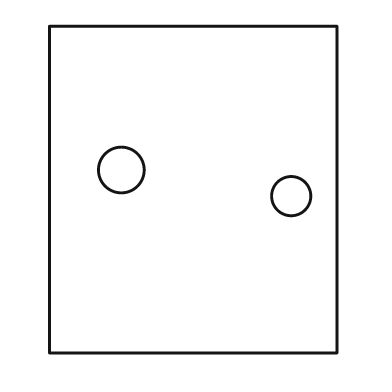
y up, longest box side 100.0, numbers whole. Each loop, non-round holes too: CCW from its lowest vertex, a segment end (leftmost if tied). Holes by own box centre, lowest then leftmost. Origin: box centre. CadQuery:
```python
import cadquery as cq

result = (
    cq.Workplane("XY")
    .moveTo(-44.0, -50.0)
    .lineTo(44.0, -50.0)
    .lineTo(44.0, 50.0)
    .lineTo(-44.0, 50.0)
    .close()
    .moveTo(30.0, -2.0)
    .circle(6.0)
    .moveTo(-22.0, 6.0)
    .circle(7.0)
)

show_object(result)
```